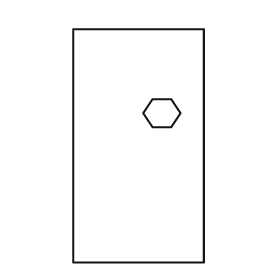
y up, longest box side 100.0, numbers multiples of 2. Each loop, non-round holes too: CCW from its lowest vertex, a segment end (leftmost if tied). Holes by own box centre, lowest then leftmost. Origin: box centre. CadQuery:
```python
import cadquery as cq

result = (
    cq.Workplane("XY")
    .moveTo(-28.0, -50.0)
    .lineTo(28.0, -50.0)
    .lineTo(28.0, 50.0)
    .lineTo(-28.0, 50.0)
    .close()
    .moveTo(6.0, 8.0)
    .lineTo(14.0, 8.0)
    .lineTo(18.0, 14.0)
    .lineTo(14.0, 20.0)
    .lineTo(6.0, 20.0)
    .lineTo(2.0, 14.0)
    .close()
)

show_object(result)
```